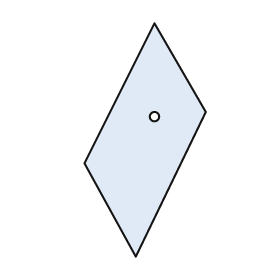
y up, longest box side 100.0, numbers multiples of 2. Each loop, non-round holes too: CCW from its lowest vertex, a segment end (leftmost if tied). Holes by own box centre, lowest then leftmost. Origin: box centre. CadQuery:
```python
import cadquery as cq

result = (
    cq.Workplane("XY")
    .moveTo(-4.0, -50.0)
    .lineTo(26.0, 12.0)
    .lineTo(4.0, 50.0)
    .lineTo(-26.0, -10.0)
    .close()
    .moveTo(4.0, 10.0)
    .circle(2.0)
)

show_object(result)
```